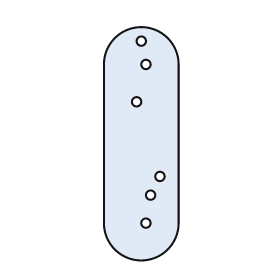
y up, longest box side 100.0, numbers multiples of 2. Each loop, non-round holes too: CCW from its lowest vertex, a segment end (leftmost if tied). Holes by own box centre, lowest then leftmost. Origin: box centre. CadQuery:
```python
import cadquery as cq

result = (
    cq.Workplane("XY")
    .moveTo(-16.0, -34.0)
    .threePointArc((0.0, -50.0), (16.0, -34.0))
    .lineTo(16.0, 34.0)
    .threePointArc((0.0, 50.0), (-16.0, 34.0))
    .close()
    .moveTo(2.0, -34.0)
    .circle(2.0)
    .moveTo(4.0, -22.0)
    .circle(2.0)
    .moveTo(8.0, -14.0)
    .circle(2.0)
    .moveTo(-2.0, 18.0)
    .circle(2.0)
    .moveTo(2.0, 34.0)
    .circle(2.0)
    .moveTo(0.0, 44.0)
    .circle(2.0)
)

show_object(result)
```